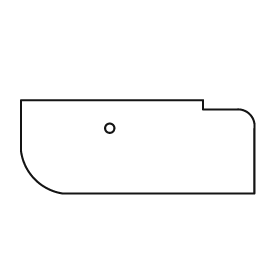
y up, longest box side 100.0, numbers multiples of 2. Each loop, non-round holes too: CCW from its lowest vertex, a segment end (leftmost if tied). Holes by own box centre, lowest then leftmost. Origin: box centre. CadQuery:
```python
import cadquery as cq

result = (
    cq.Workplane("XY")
    .moveTo(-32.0, -20.0)
    .lineTo(50.0, -20.0)
    .lineTo(50.0, 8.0)
    .threePointArc((48.0, 14.0), (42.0, 16.0))
    .lineTo(28.0, 16.0)
    .lineTo(28.0, 20.0)
    .lineTo(-50.0, 20.0)
    .lineTo(-50.0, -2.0)
    .threePointArc((-44.0, -14.0), (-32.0, -20.0))
    .close()
    .moveTo(-12.0, 8.0)
    .circle(2.0)
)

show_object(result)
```